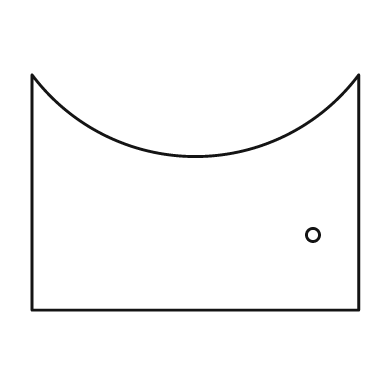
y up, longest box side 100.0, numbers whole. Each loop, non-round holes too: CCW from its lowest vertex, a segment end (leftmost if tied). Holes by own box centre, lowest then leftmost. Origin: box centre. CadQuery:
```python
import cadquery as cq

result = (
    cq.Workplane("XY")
    .moveTo(-50.0, -36.0)
    .lineTo(50.0, -36.0)
    .lineTo(50.0, 36.0)
    .threePointArc((0.0, 11.0), (-50.0, 36.0))
    .close()
    .moveTo(36.0, -13.0)
    .circle(2.0)
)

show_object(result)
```